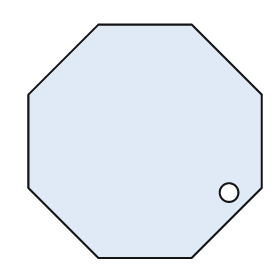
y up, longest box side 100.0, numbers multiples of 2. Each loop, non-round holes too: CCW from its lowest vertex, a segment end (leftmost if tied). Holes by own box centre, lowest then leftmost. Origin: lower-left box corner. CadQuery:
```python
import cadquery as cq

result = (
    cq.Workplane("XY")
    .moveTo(30.0, 0.0)
    .lineTo(70.0, 0.0)
    .lineTo(100.0, 30.0)
    .lineTo(100.0, 70.0)
    .lineTo(70.0, 100.0)
    .lineTo(30.0, 100.0)
    .lineTo(0.0, 70.0)
    .lineTo(0.0, 30.0)
    .close()
    .moveTo(86.0, 28.0)
    .circle(4.0)
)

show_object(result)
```